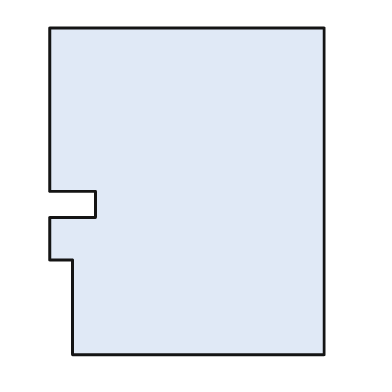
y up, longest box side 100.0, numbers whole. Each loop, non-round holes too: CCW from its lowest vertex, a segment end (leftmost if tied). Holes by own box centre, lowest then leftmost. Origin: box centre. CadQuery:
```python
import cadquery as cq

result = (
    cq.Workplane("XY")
    .moveTo(-35.0, -50.0)
    .lineTo(42.0, -50.0)
    .lineTo(42.0, 50.0)
    .lineTo(-42.0, 50.0)
    .lineTo(-42.0, 0.0)
    .lineTo(-28.0, 0.0)
    .lineTo(-28.0, -8.0)
    .lineTo(-42.0, -8.0)
    .lineTo(-42.0, -21.0)
    .lineTo(-35.0, -21.0)
    .close()
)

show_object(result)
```